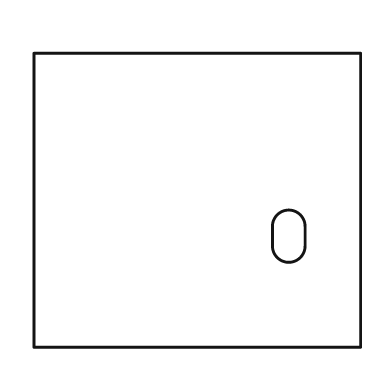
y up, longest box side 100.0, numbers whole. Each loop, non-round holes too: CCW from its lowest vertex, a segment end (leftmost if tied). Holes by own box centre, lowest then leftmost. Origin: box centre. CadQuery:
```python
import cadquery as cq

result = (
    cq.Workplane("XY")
    .moveTo(-50.0, -45.0)
    .lineTo(50.0, -45.0)
    .lineTo(50.0, 45.0)
    .lineTo(-50.0, 45.0)
    .close()
    .moveTo(23.0, -14.0)
    .threePointArc((28.0, -19.0), (33.0, -14.0))
    .lineTo(33.0, -8.0)
    .threePointArc((28.0, -3.0), (23.0, -8.0))
    .close()
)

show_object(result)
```